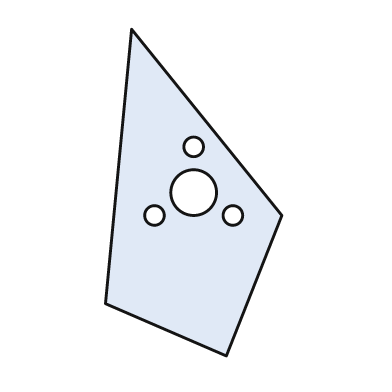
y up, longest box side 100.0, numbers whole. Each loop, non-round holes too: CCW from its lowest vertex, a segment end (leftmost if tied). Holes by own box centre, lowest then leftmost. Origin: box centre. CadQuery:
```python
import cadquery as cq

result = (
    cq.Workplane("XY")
    .moveTo(10.0, -50.0)
    .lineTo(27.0, -7.0)
    .lineTo(-19.0, 50.0)
    .lineTo(-27.0, -34.0)
    .close()
    .moveTo(-12.0, -7.0)
    .circle(3.0)
    .moveTo(12.0, -7.0)
    .circle(3.0)
    .moveTo(0.0, 0.0)
    .circle(7.0)
    .moveTo(0.0, 14.0)
    .circle(3.0)
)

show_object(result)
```